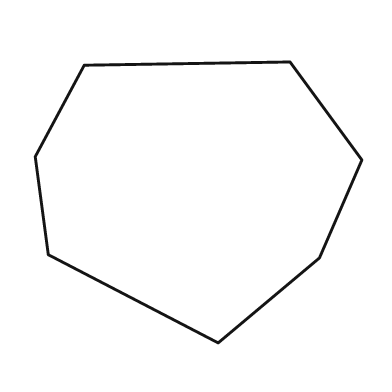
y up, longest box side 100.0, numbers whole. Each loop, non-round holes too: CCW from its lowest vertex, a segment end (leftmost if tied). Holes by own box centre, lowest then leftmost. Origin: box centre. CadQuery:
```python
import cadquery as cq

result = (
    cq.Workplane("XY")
    .moveTo(6.0, -43.0)
    .lineTo(37.0, -17.0)
    .lineTo(50.0, 13.0)
    .lineTo(28.0, 43.0)
    .lineTo(-35.0, 42.0)
    .lineTo(-50.0, 14.0)
    .lineTo(-46.0, -16.0)
    .close()
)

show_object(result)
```